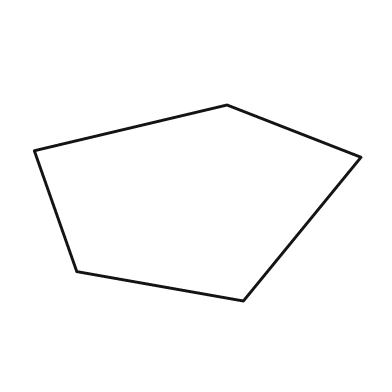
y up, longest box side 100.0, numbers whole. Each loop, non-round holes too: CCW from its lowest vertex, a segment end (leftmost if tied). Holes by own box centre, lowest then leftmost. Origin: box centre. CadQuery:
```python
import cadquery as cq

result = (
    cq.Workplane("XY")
    .moveTo(14.0, -30.0)
    .lineTo(50.0, 14.0)
    .lineTo(9.0, 30.0)
    .lineTo(-50.0, 16.0)
    .lineTo(-37.0, -21.0)
    .close()
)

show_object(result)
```